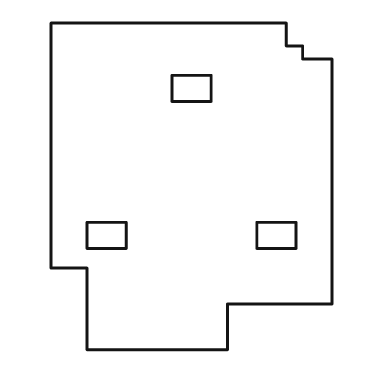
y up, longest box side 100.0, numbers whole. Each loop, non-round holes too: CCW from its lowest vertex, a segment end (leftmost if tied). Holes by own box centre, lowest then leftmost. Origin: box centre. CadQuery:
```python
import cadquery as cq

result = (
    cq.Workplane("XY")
    .moveTo(-32.0, -50.0)
    .lineTo(11.0, -50.0)
    .lineTo(11.0, -36.0)
    .lineTo(43.0, -36.0)
    .lineTo(43.0, 39.0)
    .lineTo(34.0, 39.0)
    .lineTo(34.0, 43.0)
    .lineTo(29.0, 43.0)
    .lineTo(29.0, 50.0)
    .lineTo(-43.0, 50.0)
    .lineTo(-43.0, -25.0)
    .lineTo(-32.0, -25.0)
    .close()
    .moveTo(-32.0, -19.0)
    .lineTo(-20.0, -19.0)
    .lineTo(-20.0, -11.0)
    .lineTo(-32.0, -11.0)
    .close()
    .moveTo(20.0, -19.0)
    .lineTo(32.0, -19.0)
    .lineTo(32.0, -11.0)
    .lineTo(20.0, -11.0)
    .close()
    .moveTo(-6.0, 26.0)
    .lineTo(6.0, 26.0)
    .lineTo(6.0, 34.0)
    .lineTo(-6.0, 34.0)
    .close()
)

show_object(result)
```